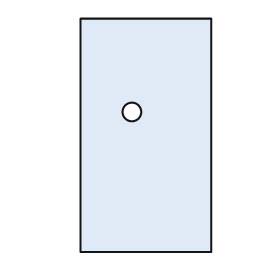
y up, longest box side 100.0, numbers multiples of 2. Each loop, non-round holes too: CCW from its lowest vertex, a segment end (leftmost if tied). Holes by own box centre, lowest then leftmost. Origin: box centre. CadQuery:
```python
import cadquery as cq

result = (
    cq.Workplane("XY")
    .moveTo(-28.0, -50.0)
    .lineTo(28.0, -50.0)
    .lineTo(28.0, 50.0)
    .lineTo(-28.0, 50.0)
    .close()
    .moveTo(-6.0, 10.0)
    .circle(4.0)
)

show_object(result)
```